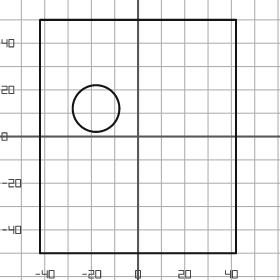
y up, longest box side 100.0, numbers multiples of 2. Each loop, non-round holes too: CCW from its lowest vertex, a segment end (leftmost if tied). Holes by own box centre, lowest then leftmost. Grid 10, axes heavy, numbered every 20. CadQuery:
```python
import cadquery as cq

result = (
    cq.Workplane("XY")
    .moveTo(-42.0, -50.0)
    .lineTo(42.0, -50.0)
    .lineTo(42.0, 50.0)
    .lineTo(-42.0, 50.0)
    .close()
    .moveTo(-18.0, 12.0)
    .circle(10.0)
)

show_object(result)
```